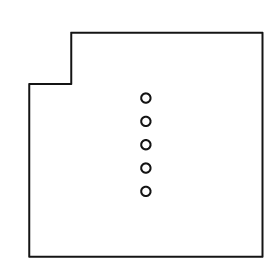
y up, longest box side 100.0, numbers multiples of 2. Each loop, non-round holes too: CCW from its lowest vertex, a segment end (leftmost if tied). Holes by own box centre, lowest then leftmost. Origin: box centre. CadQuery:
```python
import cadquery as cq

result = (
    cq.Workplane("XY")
    .moveTo(-50.0, -48.0)
    .lineTo(50.0, -48.0)
    .lineTo(50.0, 48.0)
    .lineTo(-32.0, 48.0)
    .lineTo(-32.0, 26.0)
    .lineTo(-50.0, 26.0)
    .close()
    .moveTo(0.0, -20.0)
    .circle(2.0)
    .moveTo(0.0, -10.0)
    .circle(2.0)
    .moveTo(0.0, 0.0)
    .circle(2.0)
    .moveTo(0.0, 10.0)
    .circle(2.0)
    .moveTo(0.0, 20.0)
    .circle(2.0)
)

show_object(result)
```